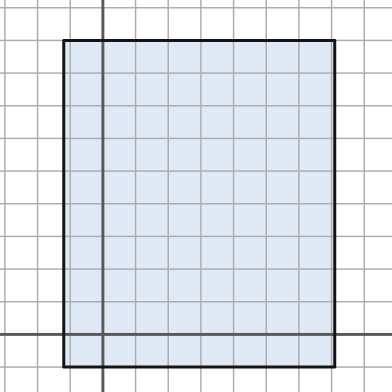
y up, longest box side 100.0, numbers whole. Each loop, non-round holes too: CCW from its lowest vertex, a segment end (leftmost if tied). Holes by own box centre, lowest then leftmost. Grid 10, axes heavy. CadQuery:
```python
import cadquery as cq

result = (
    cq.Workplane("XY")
    .moveTo(-12.0, -10.0)
    .lineTo(71.0, -10.0)
    .lineTo(71.0, 90.0)
    .lineTo(-12.0, 90.0)
    .close()
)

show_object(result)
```